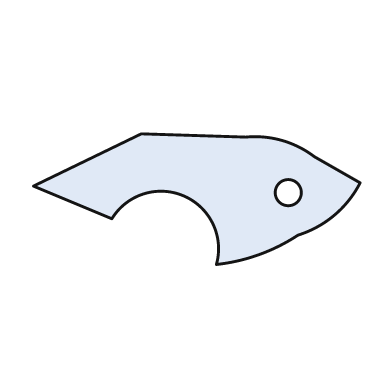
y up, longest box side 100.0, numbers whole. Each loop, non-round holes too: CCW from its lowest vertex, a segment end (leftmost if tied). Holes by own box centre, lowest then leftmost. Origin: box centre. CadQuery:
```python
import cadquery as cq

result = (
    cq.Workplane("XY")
    .moveTo(6.0, -20.0)
    .threePointArc((19.0, -17.0), (31.0, -11.0))
    .threePointArc((42.0, -5.0), (50.0, 5.0))
    .lineTo(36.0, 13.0)
    .threePointArc((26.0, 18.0), (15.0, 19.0))
    .lineTo(-17.0, 20.0)
    .lineTo(-50.0, 4.0)
    .lineTo(-26.0, -6.0)
    .threePointArc((-4.0, 1.0), (6.0, -20.0))
    .close()
    .moveTo(28.0, 2.0)
    .circle(4.0)
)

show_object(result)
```